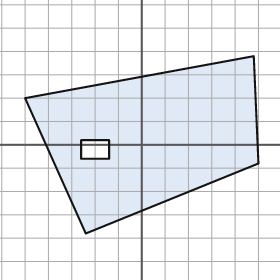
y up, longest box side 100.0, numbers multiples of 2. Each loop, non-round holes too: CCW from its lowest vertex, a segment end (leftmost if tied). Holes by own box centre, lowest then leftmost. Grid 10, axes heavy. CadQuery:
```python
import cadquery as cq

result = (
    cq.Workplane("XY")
    .moveTo(-24.0, -38.0)
    .lineTo(50.0, -8.0)
    .lineTo(48.0, 38.0)
    .lineTo(-50.0, 20.0)
    .close()
    .moveTo(-26.0, -6.0)
    .lineTo(-14.0, -6.0)
    .lineTo(-14.0, 2.0)
    .lineTo(-26.0, 2.0)
    .close()
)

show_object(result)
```